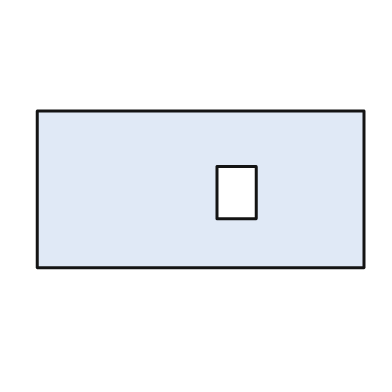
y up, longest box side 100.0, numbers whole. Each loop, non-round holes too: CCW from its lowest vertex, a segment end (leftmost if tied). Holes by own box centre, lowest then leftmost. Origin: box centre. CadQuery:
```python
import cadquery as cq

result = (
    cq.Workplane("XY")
    .moveTo(-50.0, -24.0)
    .lineTo(50.0, -24.0)
    .lineTo(50.0, 24.0)
    .lineTo(-50.0, 24.0)
    .close()
    .moveTo(5.0, -9.0)
    .lineTo(17.0, -9.0)
    .lineTo(17.0, 7.0)
    .lineTo(5.0, 7.0)
    .close()
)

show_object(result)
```